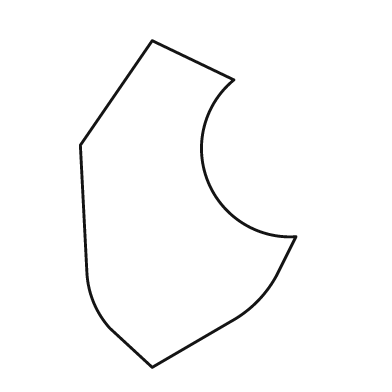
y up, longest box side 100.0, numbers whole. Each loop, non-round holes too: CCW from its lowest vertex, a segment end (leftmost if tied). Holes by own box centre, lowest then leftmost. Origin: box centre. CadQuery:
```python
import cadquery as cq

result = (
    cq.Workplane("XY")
    .moveTo(-11.0, -50.0)
    .lineTo(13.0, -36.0)
    .threePointArc((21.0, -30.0), (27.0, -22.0))
    .lineTo(33.0, -10.0)
    .threePointArc((6.0, 7.0), (14.0, 38.0))
    .lineTo(-11.0, 50.0)
    .lineTo(-33.0, 18.0)
    .lineTo(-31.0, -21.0)
    .threePointArc((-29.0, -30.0), (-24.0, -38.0))
    .close()
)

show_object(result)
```